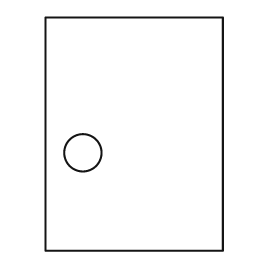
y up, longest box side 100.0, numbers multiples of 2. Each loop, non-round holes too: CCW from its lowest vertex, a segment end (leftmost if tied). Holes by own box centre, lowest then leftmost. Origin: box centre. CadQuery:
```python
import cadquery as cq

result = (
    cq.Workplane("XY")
    .moveTo(-38.0, -50.0)
    .lineTo(38.0, -50.0)
    .lineTo(38.0, 50.0)
    .lineTo(-38.0, 50.0)
    .close()
    .moveTo(-22.0, -8.0)
    .circle(8.0)
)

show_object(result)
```